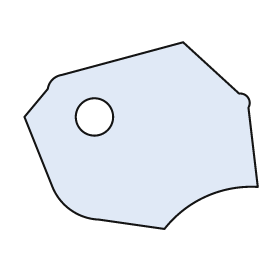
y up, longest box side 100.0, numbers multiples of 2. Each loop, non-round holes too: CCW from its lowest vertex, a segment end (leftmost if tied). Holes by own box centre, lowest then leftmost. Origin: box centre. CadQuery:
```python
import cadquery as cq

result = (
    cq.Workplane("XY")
    .moveTo(10.0, -40.0)
    .threePointArc((28.0, -26.0), (50.0, -22.0))
    .lineTo(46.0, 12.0)
    .threePointArc((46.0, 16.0), (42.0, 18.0))
    .lineTo(18.0, 40.0)
    .lineTo(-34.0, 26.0)
    .threePointArc((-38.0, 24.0), (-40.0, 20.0))
    .lineTo(-50.0, 8.0)
    .lineTo(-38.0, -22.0)
    .threePointArc((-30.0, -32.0), (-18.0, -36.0))
    .close()
    .moveTo(-20.0, 8.0)
    .circle(8.0)
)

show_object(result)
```